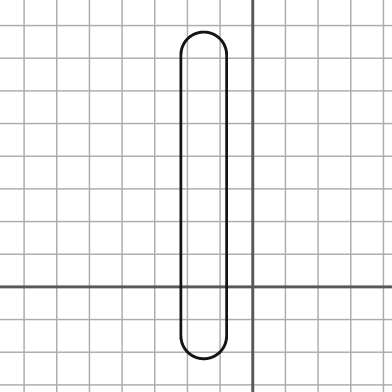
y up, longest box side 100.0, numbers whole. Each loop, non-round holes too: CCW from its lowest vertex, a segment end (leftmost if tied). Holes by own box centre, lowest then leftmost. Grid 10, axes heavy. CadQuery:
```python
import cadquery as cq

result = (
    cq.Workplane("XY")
    .moveTo(-22.0, -15.0)
    .threePointArc((-15.0, -22.0), (-8.0, -15.0))
    .lineTo(-8.0, 71.0)
    .threePointArc((-15.0, 78.0), (-22.0, 71.0))
    .close()
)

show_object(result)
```